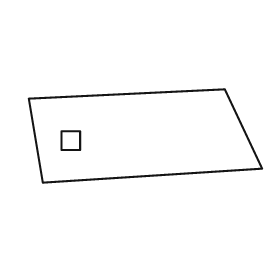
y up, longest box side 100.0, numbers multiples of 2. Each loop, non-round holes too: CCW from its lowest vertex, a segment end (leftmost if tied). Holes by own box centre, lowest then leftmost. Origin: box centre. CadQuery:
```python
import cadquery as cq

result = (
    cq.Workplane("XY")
    .moveTo(-44.0, -20.0)
    .lineTo(50.0, -14.0)
    .lineTo(34.0, 20.0)
    .lineTo(-50.0, 16.0)
    .close()
    .moveTo(-36.0, -6.0)
    .lineTo(-28.0, -6.0)
    .lineTo(-28.0, 2.0)
    .lineTo(-36.0, 2.0)
    .close()
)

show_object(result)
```